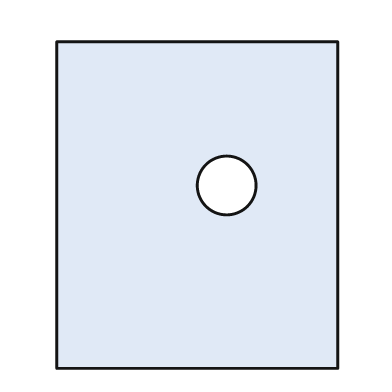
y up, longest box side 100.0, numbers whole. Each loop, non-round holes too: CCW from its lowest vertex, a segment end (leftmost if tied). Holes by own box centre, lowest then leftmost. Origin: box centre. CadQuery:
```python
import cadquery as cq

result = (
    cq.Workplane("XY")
    .moveTo(-43.0, -50.0)
    .lineTo(43.0, -50.0)
    .lineTo(43.0, 50.0)
    .lineTo(-43.0, 50.0)
    .close()
    .moveTo(9.0, 6.0)
    .circle(9.0)
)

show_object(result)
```